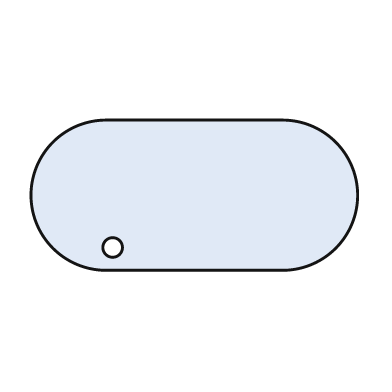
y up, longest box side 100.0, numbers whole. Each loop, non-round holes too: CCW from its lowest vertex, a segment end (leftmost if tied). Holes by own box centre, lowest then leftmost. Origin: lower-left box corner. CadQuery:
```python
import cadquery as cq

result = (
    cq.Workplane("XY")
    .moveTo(23.0, 0.0)
    .lineTo(77.0, 0.0)
    .threePointArc((100.0, 23.0), (77.0, 46.0))
    .lineTo(23.0, 46.0)
    .threePointArc((0.0, 23.0), (23.0, 0.0))
    .close()
    .moveTo(25.0, 7.0)
    .circle(3.0)
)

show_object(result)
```